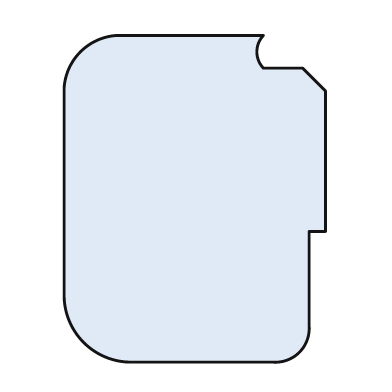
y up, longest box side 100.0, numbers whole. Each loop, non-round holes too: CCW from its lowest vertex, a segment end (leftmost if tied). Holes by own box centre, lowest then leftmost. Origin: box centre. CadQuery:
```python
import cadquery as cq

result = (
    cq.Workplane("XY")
    .moveTo(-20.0, -50.0)
    .lineTo(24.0, -50.0)
    .threePointArc((32.0, -47.0), (35.0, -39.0))
    .lineTo(35.0, -10.0)
    .lineTo(40.0, -10.0)
    .lineTo(40.0, 33.0)
    .lineTo(33.0, 40.0)
    .lineTo(21.0, 40.0)
    .threePointArc((19.0, 45.0), (21.0, 50.0))
    .lineTo(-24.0, 50.0)
    .threePointArc((-35.0, 45.0), (-40.0, 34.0))
    .lineTo(-40.0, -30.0)
    .threePointArc((-34.0, -44.0), (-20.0, -50.0))
    .close()
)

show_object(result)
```